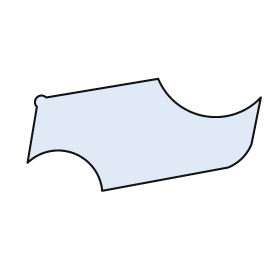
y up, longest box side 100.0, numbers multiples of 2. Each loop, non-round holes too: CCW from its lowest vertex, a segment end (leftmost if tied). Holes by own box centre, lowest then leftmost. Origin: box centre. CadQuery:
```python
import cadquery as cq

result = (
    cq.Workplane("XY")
    .moveTo(-18.0, -24.0)
    .lineTo(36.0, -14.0)
    .threePointArc((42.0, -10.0), (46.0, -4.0))
    .lineTo(50.0, 16.0)
    .threePointArc((26.0, 8.0), (6.0, 24.0))
    .lineTo(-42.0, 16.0)
    .threePointArc((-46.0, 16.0), (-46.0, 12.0))
    .lineTo(-50.0, -12.0)
    .threePointArc((-30.0, -8.0), (-18.0, -24.0))
    .close()
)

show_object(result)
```